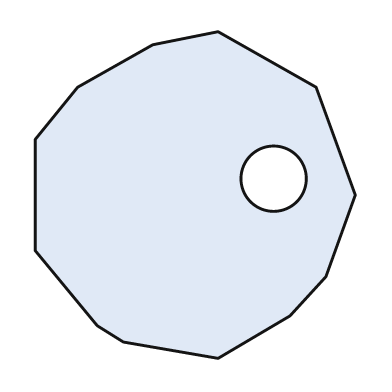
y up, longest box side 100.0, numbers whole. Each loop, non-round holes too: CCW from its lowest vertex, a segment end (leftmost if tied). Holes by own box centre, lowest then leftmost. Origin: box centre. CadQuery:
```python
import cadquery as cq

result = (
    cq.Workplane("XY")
    .moveTo(7.0, -50.0)
    .lineTo(29.0, -37.0)
    .lineTo(40.0, -25.0)
    .lineTo(49.0, 0.0)
    .lineTo(37.0, 33.0)
    .lineTo(7.0, 50.0)
    .lineTo(-13.0, 46.0)
    .lineTo(-36.0, 33.0)
    .lineTo(-49.0, 17.0)
    .lineTo(-49.0, -17.0)
    .lineTo(-30.0, -40.0)
    .lineTo(-22.0, -45.0)
    .close()
    .moveTo(24.0, 5.0)
    .circle(10.0)
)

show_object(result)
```